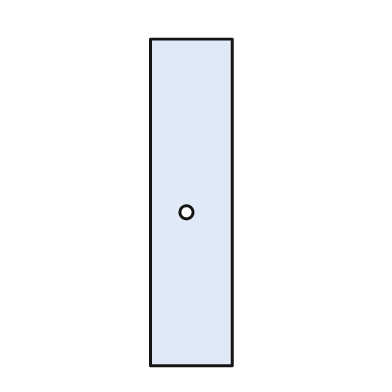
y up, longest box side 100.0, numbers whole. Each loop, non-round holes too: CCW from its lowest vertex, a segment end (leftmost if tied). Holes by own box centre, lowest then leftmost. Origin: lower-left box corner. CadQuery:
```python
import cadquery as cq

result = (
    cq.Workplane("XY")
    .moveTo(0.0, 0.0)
    .lineTo(25.0, 0.0)
    .lineTo(25.0, 100.0)
    .lineTo(0.0, 100.0)
    .close()
    .moveTo(11.0, 47.0)
    .circle(2.0)
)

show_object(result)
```